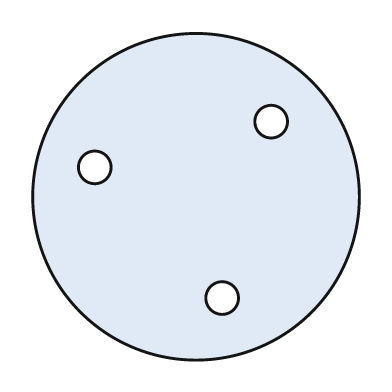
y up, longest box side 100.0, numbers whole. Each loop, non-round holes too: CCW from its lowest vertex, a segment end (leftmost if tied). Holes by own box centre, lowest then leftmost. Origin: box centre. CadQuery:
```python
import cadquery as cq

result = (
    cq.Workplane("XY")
    .moveTo(0.0, 0.0)
    .circle(50.0)
    .moveTo(8.0, -31.0)
    .circle(5.0)
    .moveTo(-31.0, 9.0)
    .circle(5.0)
    .moveTo(23.0, 23.0)
    .circle(5.0)
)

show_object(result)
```